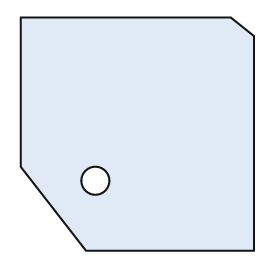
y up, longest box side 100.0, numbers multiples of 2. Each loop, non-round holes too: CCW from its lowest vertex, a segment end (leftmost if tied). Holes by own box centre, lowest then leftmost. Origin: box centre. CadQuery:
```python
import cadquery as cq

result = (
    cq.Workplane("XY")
    .moveTo(-22.0, -50.0)
    .lineTo(50.0, -50.0)
    .lineTo(50.0, 42.0)
    .lineTo(40.0, 50.0)
    .lineTo(-50.0, 50.0)
    .lineTo(-50.0, -14.0)
    .close()
    .moveTo(-18.0, -20.0)
    .circle(6.0)
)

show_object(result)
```